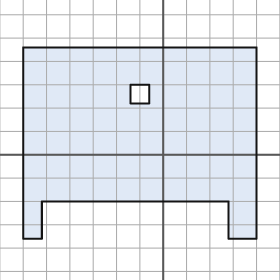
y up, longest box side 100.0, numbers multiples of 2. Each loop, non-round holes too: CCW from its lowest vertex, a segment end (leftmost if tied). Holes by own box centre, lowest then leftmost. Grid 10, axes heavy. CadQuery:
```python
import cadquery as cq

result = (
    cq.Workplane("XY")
    .moveTo(-60.0, -36.0)
    .lineTo(-52.0, -36.0)
    .lineTo(-52.0, -20.0)
    .lineTo(28.0, -20.0)
    .lineTo(28.0, -36.0)
    .lineTo(40.0, -36.0)
    .lineTo(40.0, 46.0)
    .lineTo(-60.0, 46.0)
    .close()
    .moveTo(-14.0, 22.0)
    .lineTo(-6.0, 22.0)
    .lineTo(-6.0, 30.0)
    .lineTo(-14.0, 30.0)
    .close()
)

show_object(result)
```